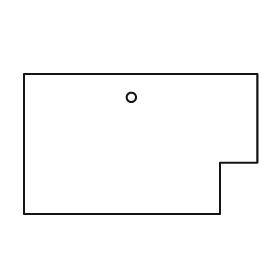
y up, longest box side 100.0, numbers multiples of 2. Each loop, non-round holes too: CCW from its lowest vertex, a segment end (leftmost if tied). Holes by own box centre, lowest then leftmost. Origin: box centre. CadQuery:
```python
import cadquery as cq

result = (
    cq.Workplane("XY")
    .moveTo(-50.0, -30.0)
    .lineTo(34.0, -30.0)
    .lineTo(34.0, -8.0)
    .lineTo(50.0, -8.0)
    .lineTo(50.0, 30.0)
    .lineTo(-50.0, 30.0)
    .close()
    .moveTo(-4.0, 20.0)
    .circle(2.0)
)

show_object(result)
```